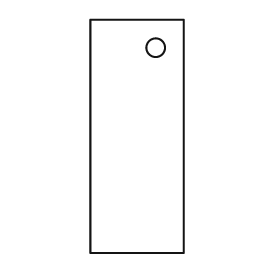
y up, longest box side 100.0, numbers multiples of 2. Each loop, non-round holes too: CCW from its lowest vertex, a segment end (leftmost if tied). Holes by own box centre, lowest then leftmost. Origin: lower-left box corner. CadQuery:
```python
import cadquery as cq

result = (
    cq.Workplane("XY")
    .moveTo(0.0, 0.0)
    .lineTo(40.0, 0.0)
    .lineTo(40.0, 100.0)
    .lineTo(0.0, 100.0)
    .close()
    .moveTo(28.0, 88.0)
    .circle(4.0)
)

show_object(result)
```